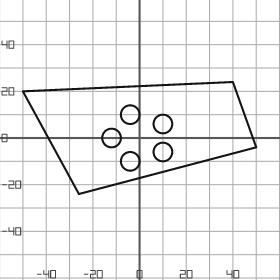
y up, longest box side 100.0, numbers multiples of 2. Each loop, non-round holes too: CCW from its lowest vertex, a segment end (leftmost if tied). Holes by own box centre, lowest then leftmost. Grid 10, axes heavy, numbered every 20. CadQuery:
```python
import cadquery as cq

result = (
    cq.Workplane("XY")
    .moveTo(-26.0, -24.0)
    .lineTo(50.0, -4.0)
    .lineTo(40.0, 24.0)
    .lineTo(-50.0, 20.0)
    .close()
    .moveTo(-4.0, -10.0)
    .circle(4.0)
    .moveTo(10.0, -6.0)
    .circle(4.0)
    .moveTo(-12.0, 0.0)
    .circle(4.0)
    .moveTo(10.0, 6.0)
    .circle(4.0)
    .moveTo(-4.0, 10.0)
    .circle(4.0)
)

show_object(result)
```